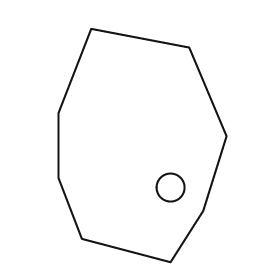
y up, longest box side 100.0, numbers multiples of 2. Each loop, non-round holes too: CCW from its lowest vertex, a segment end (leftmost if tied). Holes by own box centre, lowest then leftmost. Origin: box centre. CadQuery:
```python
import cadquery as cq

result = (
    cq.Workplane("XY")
    .moveTo(12.0, -50.0)
    .lineTo(26.0, -28.0)
    .lineTo(36.0, 4.0)
    .lineTo(20.0, 42.0)
    .lineTo(-22.0, 50.0)
    .lineTo(-36.0, 14.0)
    .lineTo(-36.0, -14.0)
    .lineTo(-26.0, -40.0)
    .close()
    .moveTo(12.0, -18.0)
    .circle(6.0)
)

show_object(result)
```